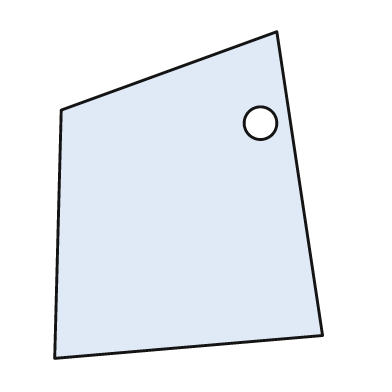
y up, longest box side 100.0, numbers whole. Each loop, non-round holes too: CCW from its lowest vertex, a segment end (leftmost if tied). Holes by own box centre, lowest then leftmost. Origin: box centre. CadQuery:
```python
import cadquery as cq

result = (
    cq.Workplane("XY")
    .moveTo(-41.0, -50.0)
    .lineTo(41.0, -43.0)
    .lineTo(27.0, 50.0)
    .lineTo(-39.0, 26.0)
    .close()
    .moveTo(22.0, 22.0)
    .circle(5.0)
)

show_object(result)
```